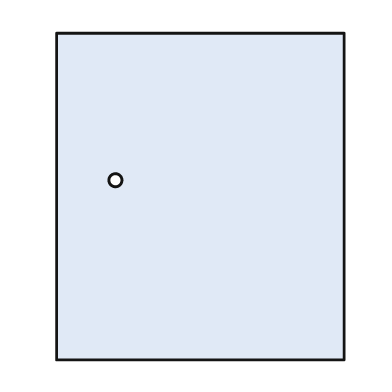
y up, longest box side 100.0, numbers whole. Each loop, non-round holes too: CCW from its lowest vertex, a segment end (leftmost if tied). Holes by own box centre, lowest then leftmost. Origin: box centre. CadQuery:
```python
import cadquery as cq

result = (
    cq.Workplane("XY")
    .moveTo(-44.0, -50.0)
    .lineTo(44.0, -50.0)
    .lineTo(44.0, 50.0)
    .lineTo(-44.0, 50.0)
    .close()
    .moveTo(-26.0, 5.0)
    .circle(2.0)
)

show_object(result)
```